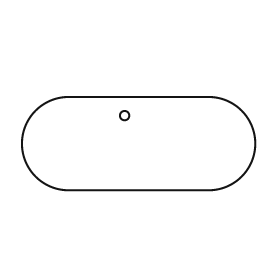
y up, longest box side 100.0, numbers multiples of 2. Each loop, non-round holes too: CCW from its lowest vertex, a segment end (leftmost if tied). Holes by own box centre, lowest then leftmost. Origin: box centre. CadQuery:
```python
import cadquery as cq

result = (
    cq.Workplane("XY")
    .moveTo(-30.0, -20.0)
    .lineTo(30.0, -20.0)
    .threePointArc((50.0, 0.0), (30.0, 20.0))
    .lineTo(-30.0, 20.0)
    .threePointArc((-50.0, 0.0), (-30.0, -20.0))
    .close()
    .moveTo(-6.0, 12.0)
    .circle(2.0)
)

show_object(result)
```